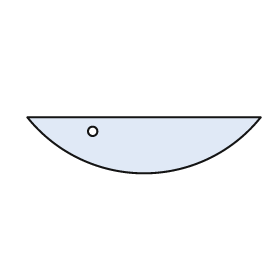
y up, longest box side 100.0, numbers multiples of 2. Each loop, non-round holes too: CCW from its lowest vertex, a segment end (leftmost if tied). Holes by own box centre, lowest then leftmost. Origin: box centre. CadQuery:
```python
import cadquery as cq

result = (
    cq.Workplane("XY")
    .moveTo(-50.0, 12.0)
    .threePointArc((0.0, -12.0), (50.0, 12.0))
    .close()
    .moveTo(-22.0, 6.0)
    .circle(2.0)
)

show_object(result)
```